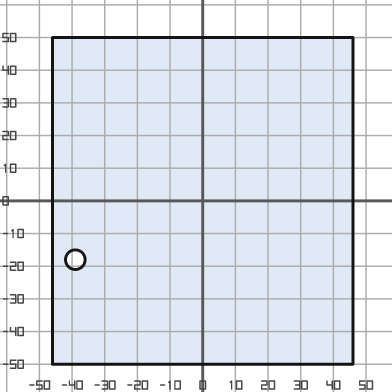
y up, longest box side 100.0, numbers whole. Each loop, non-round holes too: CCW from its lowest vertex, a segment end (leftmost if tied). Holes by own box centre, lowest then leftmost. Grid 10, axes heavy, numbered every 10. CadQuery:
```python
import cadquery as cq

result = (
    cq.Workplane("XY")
    .moveTo(-46.0, -50.0)
    .lineTo(46.0, -50.0)
    .lineTo(46.0, 50.0)
    .lineTo(-46.0, 50.0)
    .close()
    .moveTo(-39.0, -18.0)
    .circle(3.0)
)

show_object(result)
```